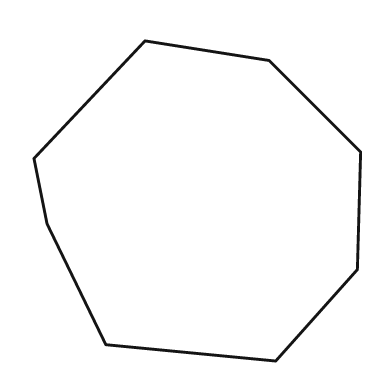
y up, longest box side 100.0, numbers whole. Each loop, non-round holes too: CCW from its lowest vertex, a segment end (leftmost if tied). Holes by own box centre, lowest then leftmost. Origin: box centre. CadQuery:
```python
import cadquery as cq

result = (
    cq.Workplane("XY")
    .moveTo(24.0, -49.0)
    .lineTo(49.0, -21.0)
    .lineTo(50.0, 15.0)
    .lineTo(22.0, 43.0)
    .lineTo(-16.0, 49.0)
    .lineTo(-50.0, 13.0)
    .lineTo(-46.0, -7.0)
    .lineTo(-28.0, -44.0)
    .close()
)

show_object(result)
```